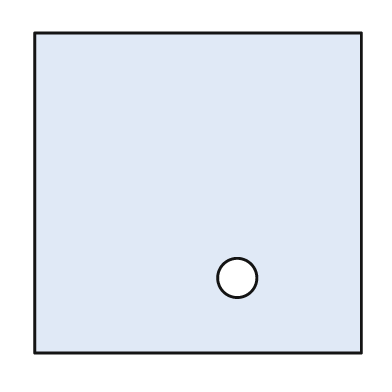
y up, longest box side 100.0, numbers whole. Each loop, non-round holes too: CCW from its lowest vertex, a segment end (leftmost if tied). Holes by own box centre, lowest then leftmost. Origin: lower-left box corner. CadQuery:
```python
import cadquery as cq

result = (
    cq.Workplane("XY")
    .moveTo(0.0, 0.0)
    .lineTo(100.0, 0.0)
    .lineTo(100.0, 98.0)
    .lineTo(0.0, 98.0)
    .close()
    .moveTo(62.0, 23.0)
    .circle(6.0)
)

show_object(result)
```